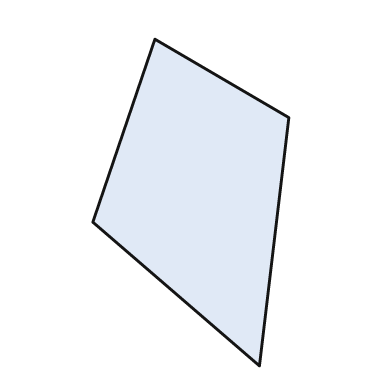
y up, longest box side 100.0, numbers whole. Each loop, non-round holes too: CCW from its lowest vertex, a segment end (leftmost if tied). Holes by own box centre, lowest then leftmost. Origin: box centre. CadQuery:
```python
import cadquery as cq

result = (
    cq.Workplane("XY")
    .moveTo(21.0, -50.0)
    .lineTo(30.0, 26.0)
    .lineTo(-11.0, 50.0)
    .lineTo(-30.0, -6.0)
    .close()
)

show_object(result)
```